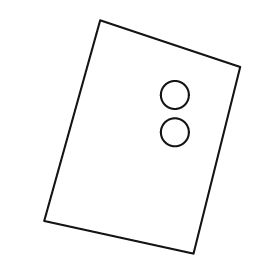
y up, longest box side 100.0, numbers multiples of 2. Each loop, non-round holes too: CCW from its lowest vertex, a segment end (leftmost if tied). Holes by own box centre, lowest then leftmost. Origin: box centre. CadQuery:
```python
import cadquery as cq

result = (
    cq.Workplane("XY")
    .moveTo(22.0, -50.0)
    .lineTo(42.0, 30.0)
    .lineTo(-18.0, 50.0)
    .lineTo(-42.0, -36.0)
    .close()
    .moveTo(14.0, 2.0)
    .circle(6.0)
    .moveTo(14.0, 18.0)
    .circle(6.0)
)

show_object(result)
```